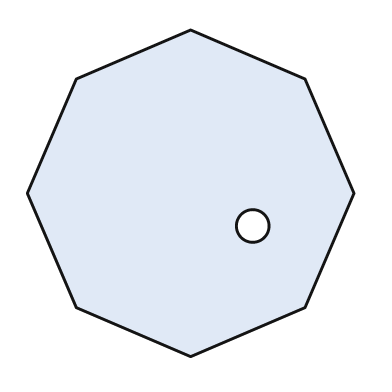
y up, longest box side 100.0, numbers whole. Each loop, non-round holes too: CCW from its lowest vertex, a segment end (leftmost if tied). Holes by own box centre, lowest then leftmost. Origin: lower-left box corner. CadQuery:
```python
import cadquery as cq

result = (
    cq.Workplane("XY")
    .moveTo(50.0, 0.0)
    .lineTo(85.0, 15.0)
    .lineTo(100.0, 50.0)
    .lineTo(85.0, 85.0)
    .lineTo(50.0, 100.0)
    .lineTo(15.0, 85.0)
    .lineTo(0.0, 50.0)
    .lineTo(15.0, 15.0)
    .close()
    .moveTo(69.0, 40.0)
    .circle(5.0)
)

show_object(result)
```